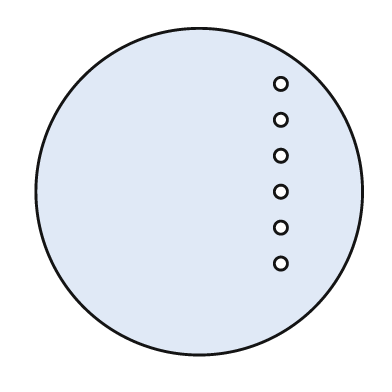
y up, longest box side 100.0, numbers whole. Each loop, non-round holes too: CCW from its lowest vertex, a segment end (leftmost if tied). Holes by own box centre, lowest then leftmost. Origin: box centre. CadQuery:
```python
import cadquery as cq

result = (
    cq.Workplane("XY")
    .moveTo(0.0, 0.0)
    .circle(50.0)
    .moveTo(25.0, -22.0)
    .circle(2.0)
    .moveTo(25.0, -11.0)
    .circle(2.0)
    .moveTo(25.0, 0.0)
    .circle(2.0)
    .moveTo(25.0, 11.0)
    .circle(2.0)
    .moveTo(25.0, 22.0)
    .circle(2.0)
    .moveTo(25.0, 33.0)
    .circle(2.0)
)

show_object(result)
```